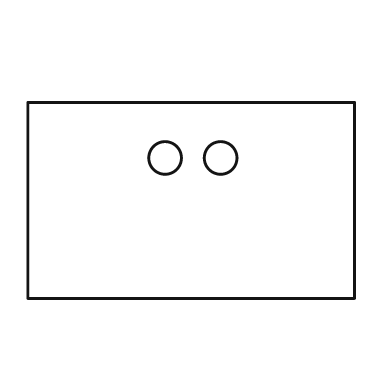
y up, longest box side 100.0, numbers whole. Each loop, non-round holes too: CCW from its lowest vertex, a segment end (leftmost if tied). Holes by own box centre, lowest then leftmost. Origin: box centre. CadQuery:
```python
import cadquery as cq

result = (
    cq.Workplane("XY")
    .moveTo(-50.0, -30.0)
    .lineTo(50.0, -30.0)
    .lineTo(50.0, 30.0)
    .lineTo(-50.0, 30.0)
    .close()
    .moveTo(-8.0, 13.0)
    .circle(5.0)
    .moveTo(9.0, 13.0)
    .circle(5.0)
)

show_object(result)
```